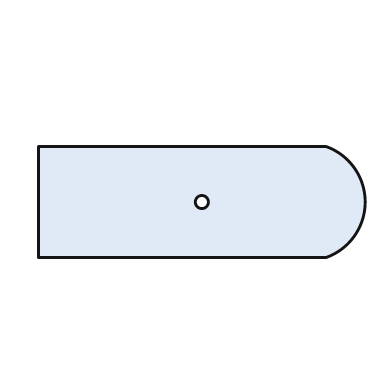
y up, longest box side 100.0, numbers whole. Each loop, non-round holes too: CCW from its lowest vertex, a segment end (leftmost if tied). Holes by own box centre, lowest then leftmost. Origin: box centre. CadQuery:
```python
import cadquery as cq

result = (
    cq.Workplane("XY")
    .moveTo(-50.0, -17.0)
    .lineTo(38.0, -17.0)
    .threePointArc((50.0, 0.0), (38.0, 17.0))
    .lineTo(-50.0, 17.0)
    .close()
    .moveTo(0.0, 0.0)
    .circle(2.0)
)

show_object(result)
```